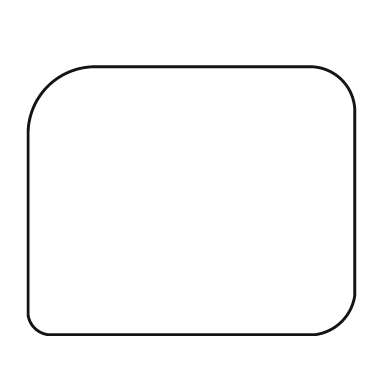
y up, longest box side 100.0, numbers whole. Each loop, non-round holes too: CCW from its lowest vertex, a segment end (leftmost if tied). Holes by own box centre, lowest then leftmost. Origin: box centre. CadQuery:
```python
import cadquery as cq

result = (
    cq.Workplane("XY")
    .moveTo(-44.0, -41.0)
    .lineTo(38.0, -41.0)
    .threePointArc((46.0, -37.0), (50.0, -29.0))
    .lineTo(50.0, 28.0)
    .threePointArc((46.0, 37.0), (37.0, 41.0))
    .lineTo(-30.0, 41.0)
    .threePointArc((-44.0, 35.0), (-50.0, 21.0))
    .lineTo(-50.0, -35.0)
    .threePointArc((-48.0, -39.0), (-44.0, -41.0))
    .close()
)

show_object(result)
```